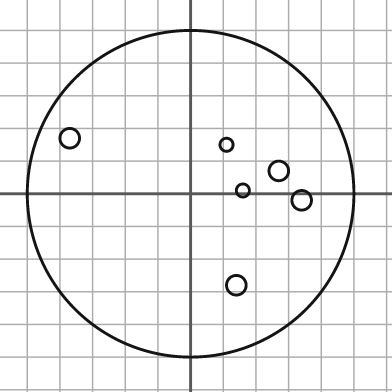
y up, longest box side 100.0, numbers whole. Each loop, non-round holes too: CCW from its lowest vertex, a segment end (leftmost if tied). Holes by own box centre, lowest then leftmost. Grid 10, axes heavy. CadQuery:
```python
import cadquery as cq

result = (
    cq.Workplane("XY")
    .moveTo(0.0, 0.0)
    .circle(50.0)
    .moveTo(14.0, -28.0)
    .circle(3.0)
    .moveTo(34.0, -2.0)
    .circle(3.0)
    .moveTo(16.0, 1.0)
    .circle(2.0)
    .moveTo(27.0, 7.0)
    .circle(3.0)
    .moveTo(11.0, 15.0)
    .circle(2.0)
    .moveTo(-37.0, 17.0)
    .circle(3.0)
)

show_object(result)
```